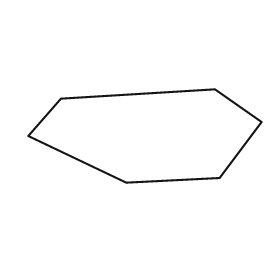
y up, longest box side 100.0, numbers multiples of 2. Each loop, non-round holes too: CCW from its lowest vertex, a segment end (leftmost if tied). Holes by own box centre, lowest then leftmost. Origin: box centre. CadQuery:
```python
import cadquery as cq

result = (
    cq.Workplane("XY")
    .moveTo(-8.0, -20.0)
    .lineTo(32.0, -18.0)
    .lineTo(50.0, 6.0)
    .lineTo(30.0, 20.0)
    .lineTo(-36.0, 16.0)
    .lineTo(-50.0, 0.0)
    .close()
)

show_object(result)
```